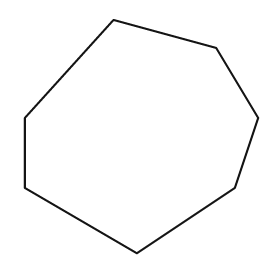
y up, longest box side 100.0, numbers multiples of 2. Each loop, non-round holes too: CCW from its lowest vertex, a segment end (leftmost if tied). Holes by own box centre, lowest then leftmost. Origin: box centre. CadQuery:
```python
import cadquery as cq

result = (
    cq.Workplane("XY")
    .moveTo(-2.0, -50.0)
    .lineTo(40.0, -22.0)
    .lineTo(50.0, 8.0)
    .lineTo(32.0, 38.0)
    .lineTo(-12.0, 50.0)
    .lineTo(-50.0, 8.0)
    .lineTo(-50.0, -22.0)
    .close()
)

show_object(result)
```